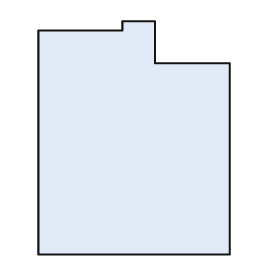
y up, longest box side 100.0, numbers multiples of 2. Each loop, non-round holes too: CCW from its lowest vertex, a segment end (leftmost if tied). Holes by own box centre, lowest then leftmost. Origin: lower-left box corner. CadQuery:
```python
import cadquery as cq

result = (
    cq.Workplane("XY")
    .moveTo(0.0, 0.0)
    .lineTo(82.0, 0.0)
    .lineTo(82.0, 82.0)
    .lineTo(50.0, 82.0)
    .lineTo(50.0, 100.0)
    .lineTo(36.0, 100.0)
    .lineTo(36.0, 96.0)
    .lineTo(0.0, 96.0)
    .close()
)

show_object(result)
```